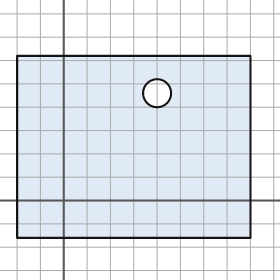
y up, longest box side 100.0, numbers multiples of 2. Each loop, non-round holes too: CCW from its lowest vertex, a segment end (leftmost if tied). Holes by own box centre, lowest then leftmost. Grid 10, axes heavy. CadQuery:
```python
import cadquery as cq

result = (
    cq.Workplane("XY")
    .moveTo(-20.0, -16.0)
    .lineTo(80.0, -16.0)
    .lineTo(80.0, 62.0)
    .lineTo(-20.0, 62.0)
    .close()
    .moveTo(40.0, 46.0)
    .circle(6.0)
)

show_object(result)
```